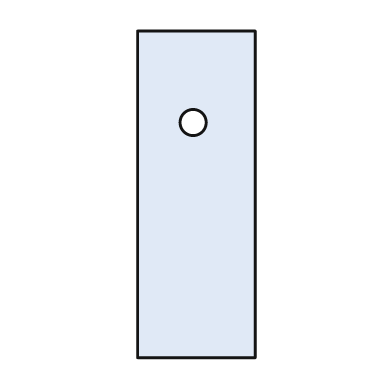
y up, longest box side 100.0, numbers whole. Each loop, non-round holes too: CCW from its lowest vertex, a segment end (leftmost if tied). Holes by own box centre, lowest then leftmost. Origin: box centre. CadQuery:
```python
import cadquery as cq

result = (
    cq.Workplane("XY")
    .moveTo(-18.0, -50.0)
    .lineTo(18.0, -50.0)
    .lineTo(18.0, 50.0)
    .lineTo(-18.0, 50.0)
    .close()
    .moveTo(-1.0, 22.0)
    .circle(4.0)
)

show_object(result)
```